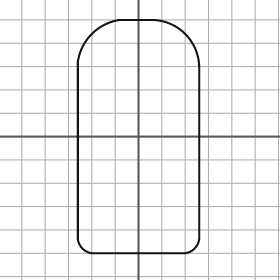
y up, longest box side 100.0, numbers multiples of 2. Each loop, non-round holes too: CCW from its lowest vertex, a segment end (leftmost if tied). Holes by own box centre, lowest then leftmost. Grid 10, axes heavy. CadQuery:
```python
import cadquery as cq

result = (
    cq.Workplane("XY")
    .moveTo(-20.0, -50.0)
    .lineTo(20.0, -50.0)
    .threePointArc((24.0, -48.0), (26.0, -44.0))
    .lineTo(26.0, 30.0)
    .threePointArc((20.0, 44.0), (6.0, 50.0))
    .lineTo(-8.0, 50.0)
    .threePointArc((-20.0, 44.0), (-26.0, 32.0))
    .lineTo(-26.0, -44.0)
    .threePointArc((-24.0, -48.0), (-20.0, -50.0))
    .close()
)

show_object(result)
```